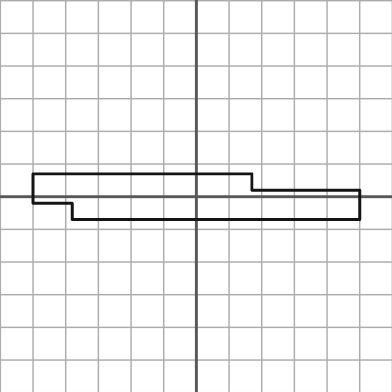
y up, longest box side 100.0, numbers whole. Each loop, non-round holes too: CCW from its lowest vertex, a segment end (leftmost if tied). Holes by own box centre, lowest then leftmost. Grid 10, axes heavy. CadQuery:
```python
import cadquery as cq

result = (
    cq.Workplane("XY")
    .moveTo(-38.0, -7.0)
    .lineTo(50.0, -7.0)
    .lineTo(50.0, 2.0)
    .lineTo(17.0, 2.0)
    .lineTo(17.0, 7.0)
    .lineTo(-50.0, 7.0)
    .lineTo(-50.0, -2.0)
    .lineTo(-38.0, -2.0)
    .close()
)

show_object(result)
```